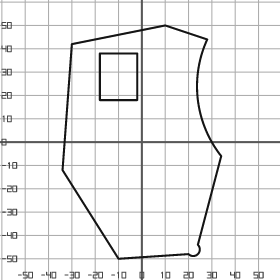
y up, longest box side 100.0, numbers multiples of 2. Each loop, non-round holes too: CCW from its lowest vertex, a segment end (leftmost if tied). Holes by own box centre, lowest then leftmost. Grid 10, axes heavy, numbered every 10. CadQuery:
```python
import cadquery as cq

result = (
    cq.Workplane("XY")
    .moveTo(-10.0, -50.0)
    .lineTo(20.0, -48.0)
    .threePointArc((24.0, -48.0), (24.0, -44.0))
    .lineTo(34.0, -6.0)
    .threePointArc((24.0, 18.0), (28.0, 44.0))
    .lineTo(10.0, 50.0)
    .lineTo(-30.0, 42.0)
    .lineTo(-34.0, -12.0)
    .close()
    .moveTo(-18.0, 18.0)
    .lineTo(-2.0, 18.0)
    .lineTo(-2.0, 38.0)
    .lineTo(-18.0, 38.0)
    .close()
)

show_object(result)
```